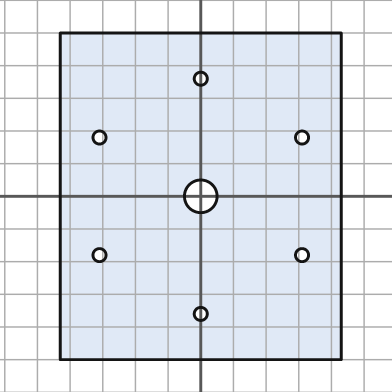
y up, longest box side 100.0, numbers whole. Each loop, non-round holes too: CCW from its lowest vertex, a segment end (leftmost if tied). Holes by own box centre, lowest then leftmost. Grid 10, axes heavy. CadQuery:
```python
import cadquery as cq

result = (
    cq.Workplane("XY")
    .moveTo(-43.0, -50.0)
    .lineTo(43.0, -50.0)
    .lineTo(43.0, 50.0)
    .lineTo(-43.0, 50.0)
    .close()
    .moveTo(0.0, -36.0)
    .circle(2.0)
    .moveTo(-31.0, -18.0)
    .circle(2.0)
    .moveTo(31.0, -18.0)
    .circle(2.0)
    .moveTo(0.0, 0.0)
    .circle(5.0)
    .moveTo(-31.0, 18.0)
    .circle(2.0)
    .moveTo(31.0, 18.0)
    .circle(2.0)
    .moveTo(0.0, 36.0)
    .circle(2.0)
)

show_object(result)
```